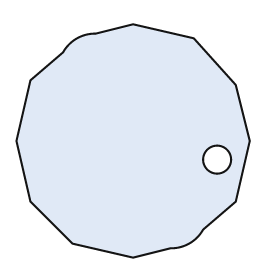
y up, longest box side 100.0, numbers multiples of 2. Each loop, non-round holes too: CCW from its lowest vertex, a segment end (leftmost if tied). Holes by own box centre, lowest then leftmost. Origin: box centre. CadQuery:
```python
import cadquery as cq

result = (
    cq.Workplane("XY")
    .moveTo(0.0, -50.0)
    .lineTo(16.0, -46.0)
    .threePointArc((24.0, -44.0), (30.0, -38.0))
    .lineTo(44.0, -26.0)
    .lineTo(50.0, 0.0)
    .lineTo(44.0, 24.0)
    .lineTo(26.0, 44.0)
    .lineTo(0.0, 50.0)
    .lineTo(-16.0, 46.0)
    .threePointArc((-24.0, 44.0), (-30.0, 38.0))
    .lineTo(-44.0, 26.0)
    .lineTo(-50.0, 0.0)
    .lineTo(-44.0, -26.0)
    .lineTo(-26.0, -44.0)
    .close()
    .moveTo(36.0, -8.0)
    .circle(6.0)
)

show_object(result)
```